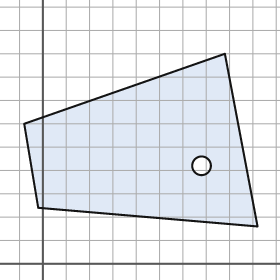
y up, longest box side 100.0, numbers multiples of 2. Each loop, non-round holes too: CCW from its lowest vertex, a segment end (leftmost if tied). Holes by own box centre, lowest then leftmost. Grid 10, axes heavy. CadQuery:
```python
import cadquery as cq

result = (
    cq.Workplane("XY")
    .moveTo(92.0, 16.0)
    .lineTo(78.0, 90.0)
    .lineTo(-8.0, 60.0)
    .lineTo(-2.0, 24.0)
    .close()
    .moveTo(68.0, 42.0)
    .circle(4.0)
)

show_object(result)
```